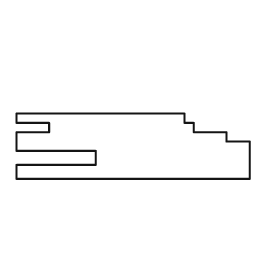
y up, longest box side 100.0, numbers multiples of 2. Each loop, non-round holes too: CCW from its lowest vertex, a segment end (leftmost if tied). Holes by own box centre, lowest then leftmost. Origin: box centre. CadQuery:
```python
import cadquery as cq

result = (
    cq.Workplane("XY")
    .moveTo(-50.0, -14.0)
    .lineTo(50.0, -14.0)
    .lineTo(50.0, 2.0)
    .lineTo(40.0, 2.0)
    .lineTo(40.0, 6.0)
    .lineTo(26.0, 6.0)
    .lineTo(26.0, 10.0)
    .lineTo(22.0, 10.0)
    .lineTo(22.0, 14.0)
    .lineTo(-50.0, 14.0)
    .lineTo(-50.0, 10.0)
    .lineTo(-36.0, 10.0)
    .lineTo(-36.0, 6.0)
    .lineTo(-50.0, 6.0)
    .lineTo(-50.0, -2.0)
    .lineTo(-16.0, -2.0)
    .lineTo(-16.0, -8.0)
    .lineTo(-50.0, -8.0)
    .close()
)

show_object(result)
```